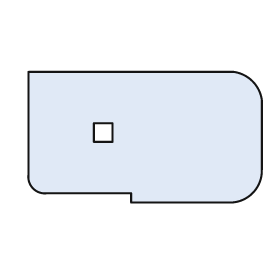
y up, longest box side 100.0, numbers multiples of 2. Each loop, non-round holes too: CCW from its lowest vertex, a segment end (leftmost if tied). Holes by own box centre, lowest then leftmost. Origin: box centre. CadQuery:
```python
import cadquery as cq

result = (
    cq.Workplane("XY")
    .moveTo(-6.0, -28.0)
    .lineTo(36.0, -28.0)
    .threePointArc((46.0, -24.0), (50.0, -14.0))
    .lineTo(50.0, 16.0)
    .threePointArc((46.0, 24.0), (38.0, 28.0))
    .lineTo(-50.0, 28.0)
    .lineTo(-50.0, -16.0)
    .threePointArc((-48.0, -22.0), (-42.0, -24.0))
    .lineTo(-6.0, -24.0)
    .close()
    .moveTo(-22.0, -2.0)
    .lineTo(-14.0, -2.0)
    .lineTo(-14.0, 6.0)
    .lineTo(-22.0, 6.0)
    .close()
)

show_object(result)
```